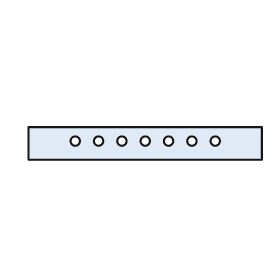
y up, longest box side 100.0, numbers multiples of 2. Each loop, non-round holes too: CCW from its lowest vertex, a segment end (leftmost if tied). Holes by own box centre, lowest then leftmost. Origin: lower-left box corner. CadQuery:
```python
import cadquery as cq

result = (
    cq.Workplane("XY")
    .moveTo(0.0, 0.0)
    .lineTo(100.0, 0.0)
    .lineTo(100.0, 14.0)
    .lineTo(0.0, 14.0)
    .close()
    .moveTo(20.0, 8.0)
    .circle(2.0)
    .moveTo(30.0, 8.0)
    .circle(2.0)
    .moveTo(40.0, 8.0)
    .circle(2.0)
    .moveTo(50.0, 8.0)
    .circle(2.0)
    .moveTo(60.0, 8.0)
    .circle(2.0)
    .moveTo(70.0, 8.0)
    .circle(2.0)
    .moveTo(80.0, 8.0)
    .circle(2.0)
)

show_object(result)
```